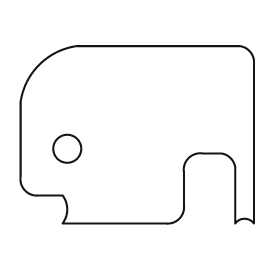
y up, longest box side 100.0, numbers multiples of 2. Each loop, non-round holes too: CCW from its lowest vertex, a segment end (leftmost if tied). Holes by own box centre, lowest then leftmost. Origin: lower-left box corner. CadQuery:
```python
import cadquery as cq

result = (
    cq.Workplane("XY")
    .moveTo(18.0, 0.0)
    .lineTo(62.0, 0.0)
    .threePointArc((68.0, 2.0), (70.0, 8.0))
    .lineTo(70.0, 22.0)
    .threePointArc((72.0, 28.0), (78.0, 30.0))
    .lineTo(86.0, 30.0)
    .threePointArc((90.0, 28.0), (92.0, 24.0))
    .lineTo(92.0, 0.0)
    .threePointArc((96.0, 2.0), (100.0, 0.0))
    .lineTo(100.0, 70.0)
    .threePointArc((98.0, 74.0), (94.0, 76.0))
    .lineTo(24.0, 76.0)
    .threePointArc((8.0, 68.0), (0.0, 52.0))
    .lineTo(0.0, 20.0)
    .threePointArc((2.0, 14.0), (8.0, 12.0))
    .lineTo(18.0, 12.0)
    .threePointArc((20.0, 6.0), (18.0, 0.0))
    .close()
    .moveTo(20.0, 32.0)
    .circle(6.0)
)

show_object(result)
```